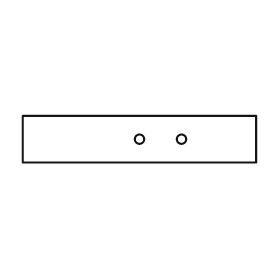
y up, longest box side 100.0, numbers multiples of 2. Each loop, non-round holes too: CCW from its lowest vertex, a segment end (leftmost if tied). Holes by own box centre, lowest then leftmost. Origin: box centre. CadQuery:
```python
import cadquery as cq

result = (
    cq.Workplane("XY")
    .moveTo(-50.0, -10.0)
    .lineTo(50.0, -10.0)
    .lineTo(50.0, 10.0)
    .lineTo(-50.0, 10.0)
    .close()
    .moveTo(0.0, 0.0)
    .circle(2.0)
    .moveTo(18.0, 0.0)
    .circle(2.0)
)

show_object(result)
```